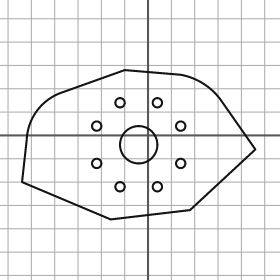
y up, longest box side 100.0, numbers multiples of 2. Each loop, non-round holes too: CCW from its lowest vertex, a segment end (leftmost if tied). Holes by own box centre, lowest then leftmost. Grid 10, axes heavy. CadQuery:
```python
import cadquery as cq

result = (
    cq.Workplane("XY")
    .moveTo(-16.0, -36.0)
    .lineTo(18.0, -32.0)
    .lineTo(46.0, -6.0)
    .lineTo(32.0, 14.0)
    .threePointArc((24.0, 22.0), (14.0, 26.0))
    .lineTo(-10.0, 28.0)
    .lineTo(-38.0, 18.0)
    .threePointArc((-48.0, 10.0), (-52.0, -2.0))
    .lineTo(-54.0, -20.0)
    .close()
    .moveTo(-12.0, -22.0)
    .circle(2.0)
    .moveTo(4.0, -22.0)
    .circle(2.0)
    .moveTo(-22.0, -12.0)
    .circle(2.0)
    .moveTo(14.0, -12.0)
    .circle(2.0)
    .moveTo(-4.0, -4.0)
    .circle(8.0)
    .moveTo(-22.0, 4.0)
    .circle(2.0)
    .moveTo(14.0, 4.0)
    .circle(2.0)
    .moveTo(-12.0, 14.0)
    .circle(2.0)
    .moveTo(4.0, 14.0)
    .circle(2.0)
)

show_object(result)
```